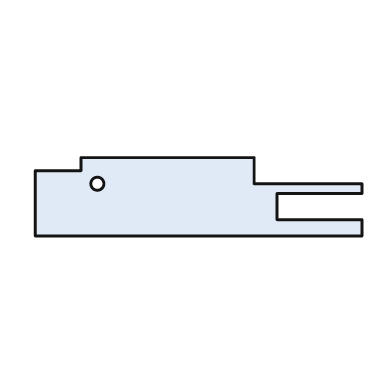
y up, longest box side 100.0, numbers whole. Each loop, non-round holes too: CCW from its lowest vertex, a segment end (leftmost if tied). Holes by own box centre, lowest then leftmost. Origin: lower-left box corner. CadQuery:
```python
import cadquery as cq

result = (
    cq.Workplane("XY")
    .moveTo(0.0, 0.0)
    .lineTo(100.0, 0.0)
    .lineTo(100.0, 5.0)
    .lineTo(74.0, 5.0)
    .lineTo(74.0, 13.0)
    .lineTo(100.0, 13.0)
    .lineTo(100.0, 16.0)
    .lineTo(67.0, 16.0)
    .lineTo(67.0, 24.0)
    .lineTo(14.0, 24.0)
    .lineTo(14.0, 20.0)
    .lineTo(0.0, 20.0)
    .close()
    .moveTo(19.0, 16.0)
    .circle(2.0)
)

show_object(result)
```